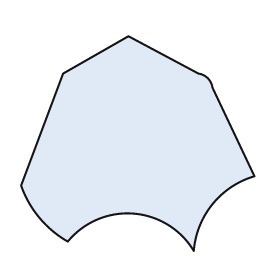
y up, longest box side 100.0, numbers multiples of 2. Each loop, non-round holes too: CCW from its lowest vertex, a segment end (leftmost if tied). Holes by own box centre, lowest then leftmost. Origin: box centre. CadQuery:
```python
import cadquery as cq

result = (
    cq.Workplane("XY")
    .moveTo(24.0, -46.0)
    .threePointArc((32.0, -26.0), (50.0, -14.0))
    .lineTo(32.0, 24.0)
    .threePointArc((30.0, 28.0), (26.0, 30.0))
    .lineTo(-4.0, 46.0)
    .lineTo(-32.0, 30.0)
    .lineTo(-50.0, -18.0)
    .threePointArc((-42.0, -32.0), (-30.0, -42.0))
    .threePointArc((-2.0, -30.0), (24.0, -46.0))
    .close()
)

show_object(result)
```